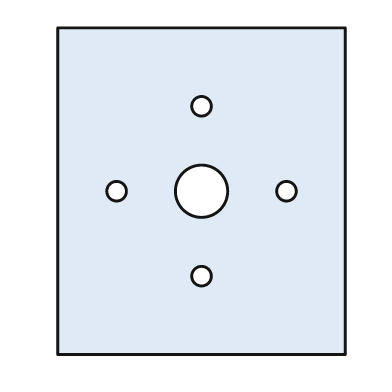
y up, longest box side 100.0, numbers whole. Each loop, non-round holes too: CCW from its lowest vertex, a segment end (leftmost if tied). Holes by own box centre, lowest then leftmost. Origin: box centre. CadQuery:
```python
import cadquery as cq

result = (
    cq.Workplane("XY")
    .moveTo(-44.0, -50.0)
    .lineTo(44.0, -50.0)
    .lineTo(44.0, 50.0)
    .lineTo(-44.0, 50.0)
    .close()
    .moveTo(0.0, -26.0)
    .circle(3.0)
    .moveTo(-26.0, 0.0)
    .circle(3.0)
    .moveTo(0.0, 0.0)
    .circle(8.0)
    .moveTo(26.0, 0.0)
    .circle(3.0)
    .moveTo(0.0, 26.0)
    .circle(3.0)
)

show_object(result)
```